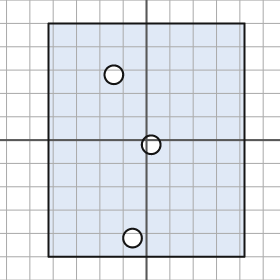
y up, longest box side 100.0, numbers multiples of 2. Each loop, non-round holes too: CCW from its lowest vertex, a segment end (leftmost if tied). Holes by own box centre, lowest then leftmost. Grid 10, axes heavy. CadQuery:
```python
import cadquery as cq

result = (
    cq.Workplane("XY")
    .moveTo(-42.0, -50.0)
    .lineTo(42.0, -50.0)
    .lineTo(42.0, 50.0)
    .lineTo(-42.0, 50.0)
    .close()
    .moveTo(-6.0, -42.0)
    .circle(4.0)
    .moveTo(2.0, -2.0)
    .circle(4.0)
    .moveTo(-14.0, 28.0)
    .circle(4.0)
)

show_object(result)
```